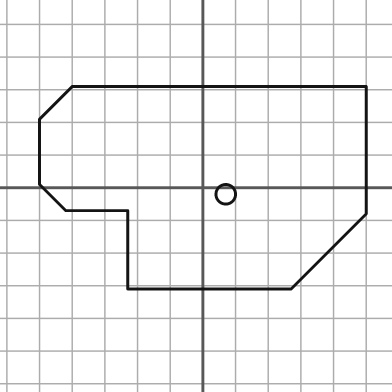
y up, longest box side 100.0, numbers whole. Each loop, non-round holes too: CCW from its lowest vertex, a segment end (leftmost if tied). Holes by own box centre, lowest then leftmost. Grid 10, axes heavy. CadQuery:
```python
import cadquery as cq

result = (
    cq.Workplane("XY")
    .moveTo(-23.0, -31.0)
    .lineTo(27.0, -31.0)
    .lineTo(50.0, -8.0)
    .lineTo(50.0, 31.0)
    .lineTo(-40.0, 31.0)
    .lineTo(-50.0, 21.0)
    .lineTo(-50.0, 1.0)
    .lineTo(-42.0, -7.0)
    .lineTo(-23.0, -7.0)
    .close()
    .moveTo(7.0, -2.0)
    .circle(3.0)
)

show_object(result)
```